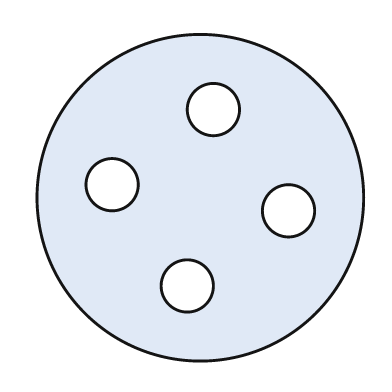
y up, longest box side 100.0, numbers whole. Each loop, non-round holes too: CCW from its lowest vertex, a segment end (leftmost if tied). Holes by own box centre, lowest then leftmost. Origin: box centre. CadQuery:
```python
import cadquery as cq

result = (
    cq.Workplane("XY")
    .moveTo(0.0, 0.0)
    .circle(50.0)
    .moveTo(-4.0, -27.0)
    .circle(8.0)
    .moveTo(27.0, -4.0)
    .circle(8.0)
    .moveTo(-27.0, 4.0)
    .circle(8.0)
    .moveTo(4.0, 27.0)
    .circle(8.0)
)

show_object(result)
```